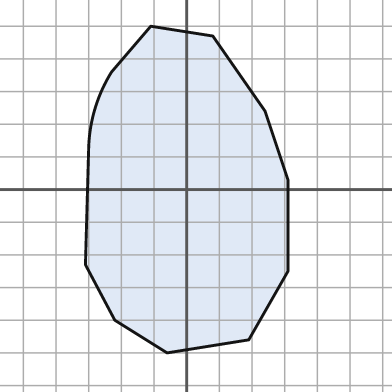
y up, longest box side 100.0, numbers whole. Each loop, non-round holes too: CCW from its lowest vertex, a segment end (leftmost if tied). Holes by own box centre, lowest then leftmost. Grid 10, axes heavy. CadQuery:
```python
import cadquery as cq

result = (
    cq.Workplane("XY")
    .moveTo(-6.0, -50.0)
    .lineTo(19.0, -46.0)
    .lineTo(31.0, -25.0)
    .lineTo(31.0, 3.0)
    .lineTo(24.0, 24.0)
    .lineTo(8.0, 47.0)
    .lineTo(-11.0, 50.0)
    .lineTo(-23.0, 36.0)
    .threePointArc((-28.0, 25.0), (-30.0, 13.0))
    .lineTo(-31.0, -23.0)
    .lineTo(-22.0, -40.0)
    .close()
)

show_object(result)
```